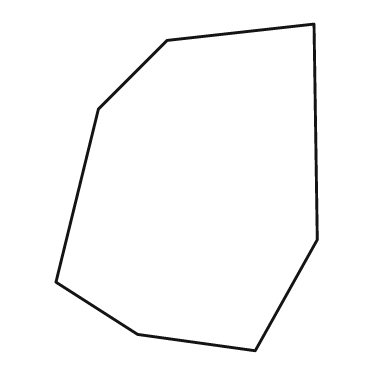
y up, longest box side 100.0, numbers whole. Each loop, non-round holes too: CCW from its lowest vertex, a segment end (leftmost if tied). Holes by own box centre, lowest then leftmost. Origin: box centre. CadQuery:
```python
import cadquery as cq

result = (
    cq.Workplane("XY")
    .moveTo(21.0, -50.0)
    .lineTo(40.0, -16.0)
    .lineTo(39.0, 50.0)
    .lineTo(-6.0, 45.0)
    .lineTo(-27.0, 24.0)
    .lineTo(-40.0, -29.0)
    .lineTo(-15.0, -45.0)
    .close()
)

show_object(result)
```